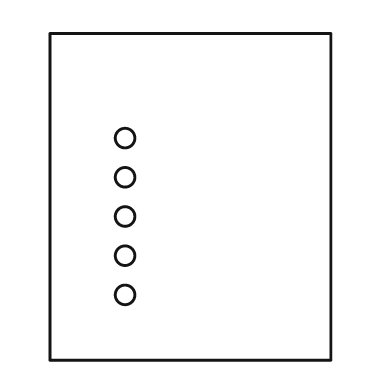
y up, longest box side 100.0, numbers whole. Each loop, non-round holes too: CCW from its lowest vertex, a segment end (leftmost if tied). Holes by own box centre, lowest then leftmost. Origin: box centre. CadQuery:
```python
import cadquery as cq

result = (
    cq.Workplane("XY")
    .moveTo(-43.0, -50.0)
    .lineTo(43.0, -50.0)
    .lineTo(43.0, 50.0)
    .lineTo(-43.0, 50.0)
    .close()
    .moveTo(-20.0, -30.0)
    .circle(3.0)
    .moveTo(-20.0, -18.0)
    .circle(3.0)
    .moveTo(-20.0, -6.0)
    .circle(3.0)
    .moveTo(-20.0, 6.0)
    .circle(3.0)
    .moveTo(-20.0, 18.0)
    .circle(3.0)
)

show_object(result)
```